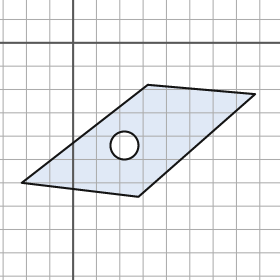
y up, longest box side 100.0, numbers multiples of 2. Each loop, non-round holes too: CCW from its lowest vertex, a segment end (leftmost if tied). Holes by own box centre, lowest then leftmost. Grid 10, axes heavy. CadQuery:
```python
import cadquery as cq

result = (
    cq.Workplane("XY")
    .moveTo(28.0, -66.0)
    .lineTo(78.0, -22.0)
    .lineTo(32.0, -18.0)
    .lineTo(-22.0, -60.0)
    .close()
    .moveTo(22.0, -44.0)
    .circle(6.0)
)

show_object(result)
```